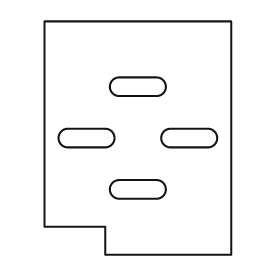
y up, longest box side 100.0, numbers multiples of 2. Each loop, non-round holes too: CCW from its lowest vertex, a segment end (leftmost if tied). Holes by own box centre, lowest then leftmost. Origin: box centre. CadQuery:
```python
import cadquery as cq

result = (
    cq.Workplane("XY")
    .moveTo(-14.0, -50.0)
    .lineTo(40.0, -50.0)
    .lineTo(40.0, 50.0)
    .lineTo(-40.0, 50.0)
    .lineTo(-40.0, -38.0)
    .lineTo(-14.0, -38.0)
    .close()
    .moveTo(-8.0, -26.0)
    .lineTo(8.0, -26.0)
    .threePointArc((12.0, -22.0), (8.0, -18.0))
    .lineTo(-8.0, -18.0)
    .threePointArc((-12.0, -22.0), (-8.0, -26.0))
    .close()
    .moveTo(-30.0, -4.0)
    .lineTo(-14.0, -4.0)
    .threePointArc((-10.0, 0.0), (-14.0, 4.0))
    .lineTo(-30.0, 4.0)
    .threePointArc((-34.0, 0.0), (-30.0, -4.0))
    .close()
    .moveTo(14.0, -4.0)
    .lineTo(30.0, -4.0)
    .threePointArc((34.0, 0.0), (30.0, 4.0))
    .lineTo(14.0, 4.0)
    .threePointArc((10.0, 0.0), (14.0, -4.0))
    .close()
    .moveTo(-8.0, 18.0)
    .lineTo(8.0, 18.0)
    .threePointArc((12.0, 22.0), (8.0, 26.0))
    .lineTo(-8.0, 26.0)
    .threePointArc((-12.0, 22.0), (-8.0, 18.0))
    .close()
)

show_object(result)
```